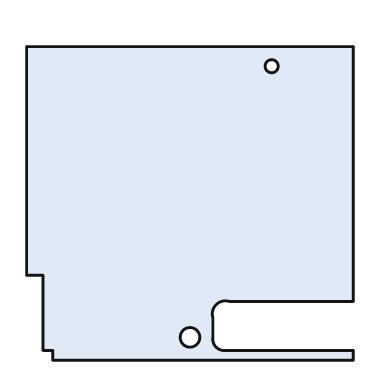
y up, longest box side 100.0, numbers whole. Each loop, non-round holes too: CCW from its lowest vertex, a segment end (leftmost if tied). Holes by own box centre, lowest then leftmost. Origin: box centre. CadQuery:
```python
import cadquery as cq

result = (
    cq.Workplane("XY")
    .moveTo(-42.0, -48.0)
    .lineTo(50.0, -48.0)
    .lineTo(50.0, -45.0)
    .lineTo(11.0, -45.0)
    .threePointArc((8.0, -44.0), (7.0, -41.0))
    .lineTo(7.0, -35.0)
    .threePointArc((8.0, -31.0), (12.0, -30.0))
    .lineTo(50.0, -30.0)
    .lineTo(50.0, 48.0)
    .lineTo(-50.0, 48.0)
    .lineTo(-50.0, -22.0)
    .lineTo(-45.0, -22.0)
    .lineTo(-45.0, -45.0)
    .lineTo(-42.0, -45.0)
    .close()
    .moveTo(0.0, -41.0)
    .circle(3.0)
    .moveTo(25.0, 42.0)
    .circle(2.0)
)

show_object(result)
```